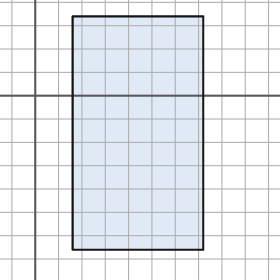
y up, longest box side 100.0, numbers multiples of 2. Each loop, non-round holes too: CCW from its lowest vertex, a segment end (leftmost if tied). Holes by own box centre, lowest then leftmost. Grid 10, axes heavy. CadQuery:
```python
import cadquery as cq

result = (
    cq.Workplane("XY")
    .moveTo(16.0, -66.0)
    .lineTo(72.0, -66.0)
    .lineTo(72.0, 34.0)
    .lineTo(16.0, 34.0)
    .close()
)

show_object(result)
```